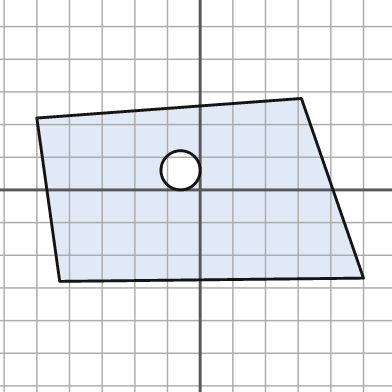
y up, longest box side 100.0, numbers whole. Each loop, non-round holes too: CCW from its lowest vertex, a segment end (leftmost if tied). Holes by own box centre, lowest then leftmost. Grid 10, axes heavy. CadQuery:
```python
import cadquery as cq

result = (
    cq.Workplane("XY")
    .moveTo(-43.0, -28.0)
    .lineTo(50.0, -27.0)
    .lineTo(31.0, 28.0)
    .lineTo(-50.0, 22.0)
    .close()
    .moveTo(-6.0, 6.0)
    .circle(6.0)
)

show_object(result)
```